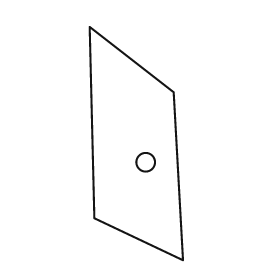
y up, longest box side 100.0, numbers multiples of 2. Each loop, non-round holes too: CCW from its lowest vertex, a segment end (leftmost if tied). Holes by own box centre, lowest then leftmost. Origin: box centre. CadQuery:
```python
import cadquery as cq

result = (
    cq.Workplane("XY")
    .moveTo(20.0, -50.0)
    .lineTo(16.0, 22.0)
    .lineTo(-20.0, 50.0)
    .lineTo(-18.0, -32.0)
    .close()
    .moveTo(4.0, -8.0)
    .circle(4.0)
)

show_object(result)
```